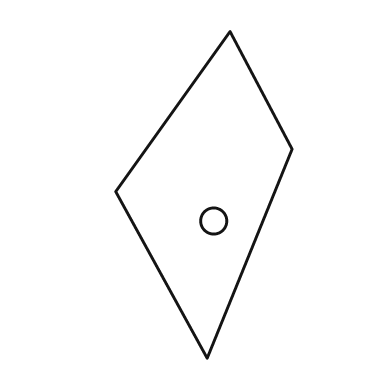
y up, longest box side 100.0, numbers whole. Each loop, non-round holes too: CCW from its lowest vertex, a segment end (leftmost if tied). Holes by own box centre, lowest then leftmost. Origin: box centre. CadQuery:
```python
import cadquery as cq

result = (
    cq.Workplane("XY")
    .moveTo(1.0, -50.0)
    .lineTo(27.0, 14.0)
    .lineTo(8.0, 50.0)
    .lineTo(-27.0, 1.0)
    .close()
    .moveTo(3.0, -8.0)
    .circle(4.0)
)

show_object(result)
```